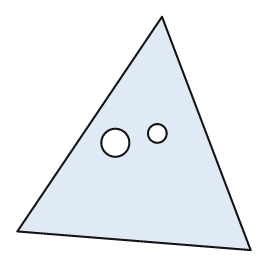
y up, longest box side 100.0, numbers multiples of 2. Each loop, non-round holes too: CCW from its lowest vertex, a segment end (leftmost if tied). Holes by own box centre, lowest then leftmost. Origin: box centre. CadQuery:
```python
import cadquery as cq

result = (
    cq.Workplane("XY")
    .moveTo(50.0, -50.0)
    .lineTo(12.0, 50.0)
    .lineTo(-50.0, -42.0)
    .close()
    .moveTo(-8.0, -4.0)
    .circle(6.0)
    .moveTo(10.0, 0.0)
    .circle(4.0)
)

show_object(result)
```